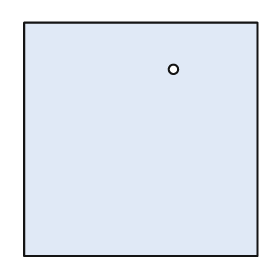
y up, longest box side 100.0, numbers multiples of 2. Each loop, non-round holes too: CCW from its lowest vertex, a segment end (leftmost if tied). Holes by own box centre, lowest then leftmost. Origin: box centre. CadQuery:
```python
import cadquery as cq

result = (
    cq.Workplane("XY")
    .moveTo(-50.0, -50.0)
    .lineTo(50.0, -50.0)
    .lineTo(50.0, 50.0)
    .lineTo(-50.0, 50.0)
    .close()
    .moveTo(14.0, 30.0)
    .circle(2.0)
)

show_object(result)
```